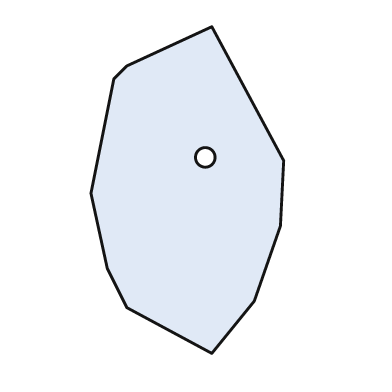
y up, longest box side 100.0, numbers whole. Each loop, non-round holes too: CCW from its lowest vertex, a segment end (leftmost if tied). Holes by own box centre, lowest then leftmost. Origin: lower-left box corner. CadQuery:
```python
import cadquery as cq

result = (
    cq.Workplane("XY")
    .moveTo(37.0, 0.0)
    .lineTo(50.0, 16.0)
    .lineTo(58.0, 39.0)
    .lineTo(59.0, 59.0)
    .lineTo(37.0, 100.0)
    .lineTo(11.0, 88.0)
    .lineTo(7.0, 84.0)
    .lineTo(0.0, 49.0)
    .lineTo(5.0, 26.0)
    .lineTo(11.0, 14.0)
    .close()
    .moveTo(35.0, 60.0)
    .circle(3.0)
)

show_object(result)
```